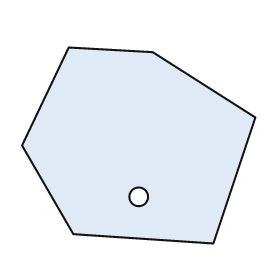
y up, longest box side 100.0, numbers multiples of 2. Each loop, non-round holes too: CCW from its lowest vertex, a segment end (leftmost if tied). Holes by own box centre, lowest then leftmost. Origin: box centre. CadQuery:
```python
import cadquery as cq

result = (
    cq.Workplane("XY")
    .moveTo(32.0, -42.0)
    .lineTo(50.0, 12.0)
    .lineTo(6.0, 40.0)
    .lineTo(-30.0, 42.0)
    .lineTo(-50.0, 0.0)
    .lineTo(-28.0, -38.0)
    .close()
    .moveTo(0.0, -22.0)
    .circle(4.0)
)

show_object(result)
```